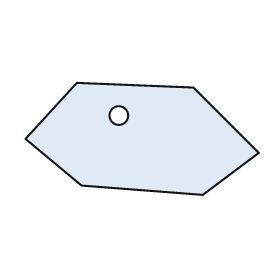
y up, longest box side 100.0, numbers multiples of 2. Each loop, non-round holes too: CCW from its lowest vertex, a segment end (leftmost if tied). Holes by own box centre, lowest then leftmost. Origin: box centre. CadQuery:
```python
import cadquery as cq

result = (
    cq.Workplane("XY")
    .moveTo(26.0, -24.0)
    .lineTo(50.0, -6.0)
    .lineTo(22.0, 22.0)
    .lineTo(-28.0, 24.0)
    .lineTo(-50.0, 0.0)
    .lineTo(-26.0, -20.0)
    .close()
    .moveTo(-10.0, 10.0)
    .circle(4.0)
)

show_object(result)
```